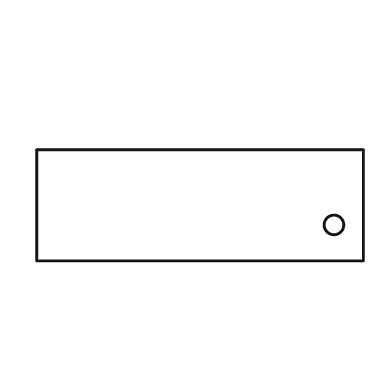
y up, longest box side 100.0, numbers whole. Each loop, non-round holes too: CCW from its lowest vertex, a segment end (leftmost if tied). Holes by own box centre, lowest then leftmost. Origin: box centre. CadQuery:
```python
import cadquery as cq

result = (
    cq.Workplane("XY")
    .moveTo(-50.0, -17.0)
    .lineTo(50.0, -17.0)
    .lineTo(50.0, 17.0)
    .lineTo(-50.0, 17.0)
    .close()
    .moveTo(41.0, -6.0)
    .circle(3.0)
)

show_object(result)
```